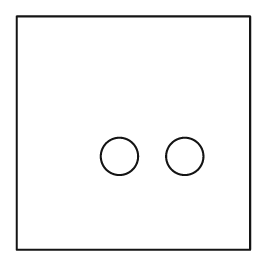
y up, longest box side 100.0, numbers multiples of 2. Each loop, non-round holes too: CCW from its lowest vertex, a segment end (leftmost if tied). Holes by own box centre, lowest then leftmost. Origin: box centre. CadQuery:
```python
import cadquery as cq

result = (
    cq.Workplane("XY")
    .moveTo(-50.0, -50.0)
    .lineTo(50.0, -50.0)
    .lineTo(50.0, 50.0)
    .lineTo(-50.0, 50.0)
    .close()
    .moveTo(-6.0, -10.0)
    .circle(8.0)
    .moveTo(22.0, -10.0)
    .circle(8.0)
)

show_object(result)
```